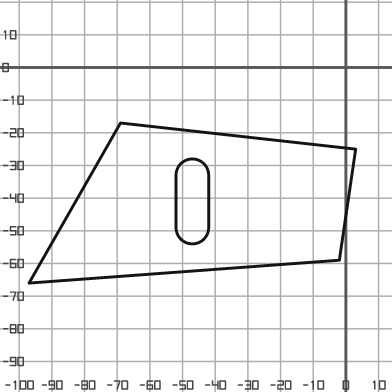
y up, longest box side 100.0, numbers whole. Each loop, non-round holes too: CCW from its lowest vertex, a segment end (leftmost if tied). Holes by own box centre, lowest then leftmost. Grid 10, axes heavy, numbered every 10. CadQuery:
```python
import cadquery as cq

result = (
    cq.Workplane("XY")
    .moveTo(-97.0, -66.0)
    .lineTo(-2.0, -59.0)
    .lineTo(3.0, -25.0)
    .lineTo(-69.0, -17.0)
    .close()
    .moveTo(-52.0, -49.0)
    .threePointArc((-47.0, -54.0), (-42.0, -49.0))
    .lineTo(-42.0, -33.0)
    .threePointArc((-47.0, -28.0), (-52.0, -33.0))
    .close()
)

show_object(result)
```